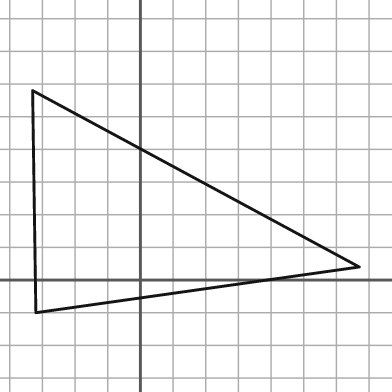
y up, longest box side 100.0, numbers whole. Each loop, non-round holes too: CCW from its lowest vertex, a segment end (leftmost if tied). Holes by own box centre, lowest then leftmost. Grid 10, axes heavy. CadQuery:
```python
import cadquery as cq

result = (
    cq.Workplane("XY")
    .moveTo(-32.0, -10.0)
    .lineTo(67.0, 4.0)
    .lineTo(-33.0, 58.0)
    .close()
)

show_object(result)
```